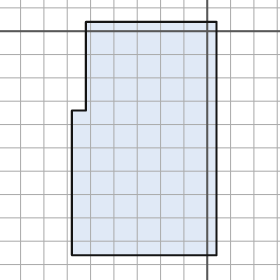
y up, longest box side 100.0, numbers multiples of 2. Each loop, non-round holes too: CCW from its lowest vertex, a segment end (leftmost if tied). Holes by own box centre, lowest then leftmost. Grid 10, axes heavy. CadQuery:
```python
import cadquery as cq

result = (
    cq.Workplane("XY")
    .moveTo(-58.0, -96.0)
    .lineTo(4.0, -96.0)
    .lineTo(4.0, 4.0)
    .lineTo(-52.0, 4.0)
    .lineTo(-52.0, -34.0)
    .lineTo(-58.0, -34.0)
    .close()
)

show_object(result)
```